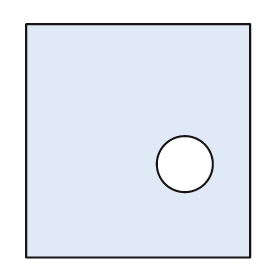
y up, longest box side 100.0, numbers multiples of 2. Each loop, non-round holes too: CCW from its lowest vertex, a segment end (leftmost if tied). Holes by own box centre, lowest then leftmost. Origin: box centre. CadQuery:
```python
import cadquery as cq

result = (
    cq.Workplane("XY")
    .moveTo(-48.0, -50.0)
    .lineTo(48.0, -50.0)
    .lineTo(48.0, 50.0)
    .lineTo(-48.0, 50.0)
    .close()
    .moveTo(20.0, -10.0)
    .circle(12.0)
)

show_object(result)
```